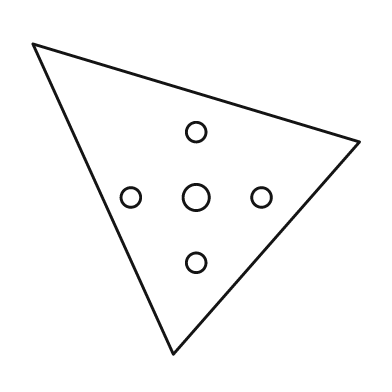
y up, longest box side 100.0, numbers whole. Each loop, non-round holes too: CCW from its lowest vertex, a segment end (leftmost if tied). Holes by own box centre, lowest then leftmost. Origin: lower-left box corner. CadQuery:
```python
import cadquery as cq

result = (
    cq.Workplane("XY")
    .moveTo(43.0, 0.0)
    .lineTo(100.0, 65.0)
    .lineTo(0.0, 95.0)
    .close()
    .moveTo(50.0, 28.0)
    .circle(3.0)
    .moveTo(30.0, 48.0)
    .circle(3.0)
    .moveTo(50.0, 48.0)
    .circle(4.0)
    .moveTo(70.0, 48.0)
    .circle(3.0)
    .moveTo(50.0, 68.0)
    .circle(3.0)
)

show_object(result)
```